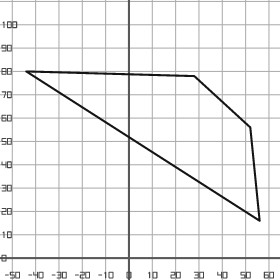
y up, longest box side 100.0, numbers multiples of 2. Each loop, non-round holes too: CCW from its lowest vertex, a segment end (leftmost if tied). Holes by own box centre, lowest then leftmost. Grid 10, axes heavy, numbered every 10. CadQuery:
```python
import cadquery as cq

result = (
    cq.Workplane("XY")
    .moveTo(56.0, 16.0)
    .lineTo(52.0, 56.0)
    .lineTo(28.0, 78.0)
    .lineTo(-44.0, 80.0)
    .close()
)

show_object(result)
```